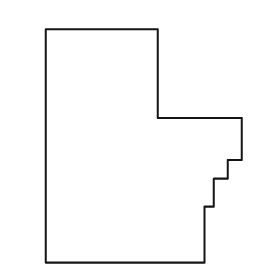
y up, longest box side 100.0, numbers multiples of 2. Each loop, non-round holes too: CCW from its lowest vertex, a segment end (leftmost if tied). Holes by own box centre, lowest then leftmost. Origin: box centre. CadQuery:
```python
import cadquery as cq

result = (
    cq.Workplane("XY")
    .moveTo(-42.0, -50.0)
    .lineTo(26.0, -50.0)
    .lineTo(26.0, -26.0)
    .lineTo(30.0, -26.0)
    .lineTo(30.0, -14.0)
    .lineTo(36.0, -14.0)
    .lineTo(36.0, -6.0)
    .lineTo(42.0, -6.0)
    .lineTo(42.0, 12.0)
    .lineTo(6.0, 12.0)
    .lineTo(6.0, 50.0)
    .lineTo(-42.0, 50.0)
    .close()
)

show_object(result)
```